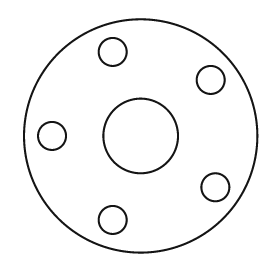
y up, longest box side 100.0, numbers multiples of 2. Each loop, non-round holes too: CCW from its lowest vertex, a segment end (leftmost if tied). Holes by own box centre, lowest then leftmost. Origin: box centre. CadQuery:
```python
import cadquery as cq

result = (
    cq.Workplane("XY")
    .moveTo(0.0, 0.0)
    .circle(50.0)
    .moveTo(-12.0, -36.0)
    .circle(6.0)
    .moveTo(32.0, -22.0)
    .circle(6.0)
    .moveTo(-38.0, 0.0)
    .circle(6.0)
    .moveTo(0.0, 0.0)
    .circle(16.0)
    .moveTo(30.0, 24.0)
    .circle(6.0)
    .moveTo(-12.0, 36.0)
    .circle(6.0)
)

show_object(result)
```